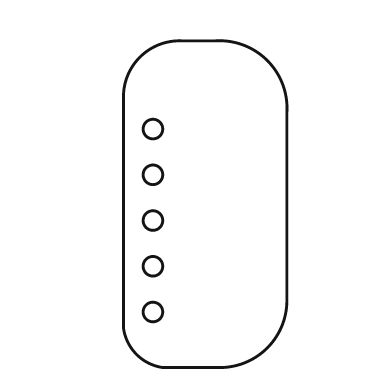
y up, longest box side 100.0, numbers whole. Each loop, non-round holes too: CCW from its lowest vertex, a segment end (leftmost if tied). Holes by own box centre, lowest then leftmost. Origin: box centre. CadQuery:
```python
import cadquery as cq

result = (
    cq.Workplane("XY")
    .moveTo(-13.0, -50.0)
    .lineTo(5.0, -50.0)
    .threePointArc((19.0, -44.0), (25.0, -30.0))
    .lineTo(25.0, 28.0)
    .threePointArc((19.0, 44.0), (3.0, 50.0))
    .lineTo(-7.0, 50.0)
    .threePointArc((-20.0, 45.0), (-25.0, 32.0))
    .lineTo(-25.0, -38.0)
    .threePointArc((-21.0, -46.0), (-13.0, -50.0))
    .close()
    .moveTo(-16.0, -33.0)
    .circle(3.0)
    .moveTo(-16.0, -19.0)
    .circle(3.0)
    .moveTo(-16.0, -5.0)
    .circle(3.0)
    .moveTo(-16.0, 9.0)
    .circle(3.0)
    .moveTo(-16.0, 23.0)
    .circle(3.0)
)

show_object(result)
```